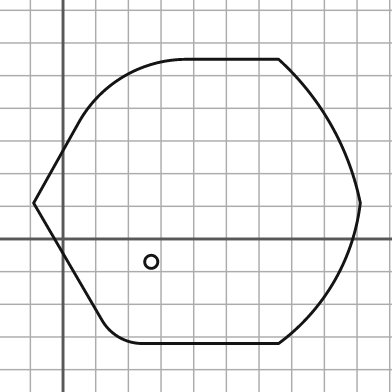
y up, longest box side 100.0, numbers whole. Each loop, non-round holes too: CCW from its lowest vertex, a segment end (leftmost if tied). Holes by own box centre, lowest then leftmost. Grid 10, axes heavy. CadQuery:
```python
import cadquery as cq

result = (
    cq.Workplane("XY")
    .moveTo(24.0, -32.0)
    .lineTo(66.0, -32.0)
    .threePointArc((83.0, -13.0), (91.0, 11.0))
    .threePointArc((82.0, 35.0), (66.0, 55.0))
    .lineTo(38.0, 55.0)
    .threePointArc((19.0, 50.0), (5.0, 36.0))
    .lineTo(-9.0, 11.0)
    .lineTo(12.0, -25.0)
    .threePointArc((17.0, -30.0), (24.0, -32.0))
    .close()
    .moveTo(27.0, -7.0)
    .circle(2.0)
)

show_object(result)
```